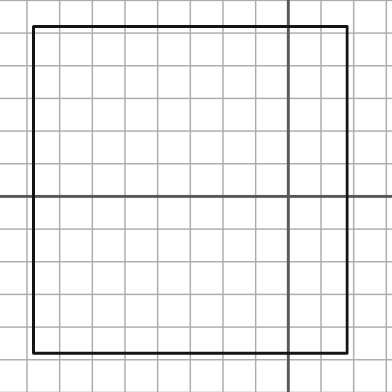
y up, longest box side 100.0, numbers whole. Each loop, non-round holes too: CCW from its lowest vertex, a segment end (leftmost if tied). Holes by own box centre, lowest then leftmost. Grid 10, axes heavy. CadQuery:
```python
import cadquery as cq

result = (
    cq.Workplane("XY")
    .moveTo(-78.0, -48.0)
    .lineTo(18.0, -48.0)
    .lineTo(18.0, 52.0)
    .lineTo(-78.0, 52.0)
    .close()
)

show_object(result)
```